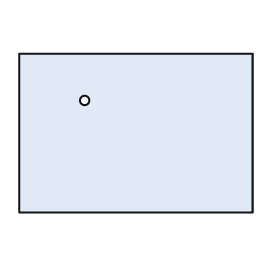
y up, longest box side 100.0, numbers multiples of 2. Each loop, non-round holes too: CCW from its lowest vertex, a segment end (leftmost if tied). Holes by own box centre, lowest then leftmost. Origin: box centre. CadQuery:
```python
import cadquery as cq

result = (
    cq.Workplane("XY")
    .moveTo(-50.0, -34.0)
    .lineTo(50.0, -34.0)
    .lineTo(50.0, 34.0)
    .lineTo(-50.0, 34.0)
    .close()
    .moveTo(-22.0, 14.0)
    .circle(2.0)
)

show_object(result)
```